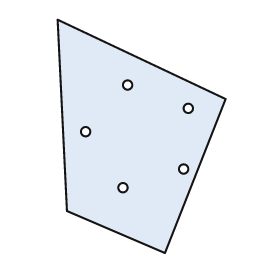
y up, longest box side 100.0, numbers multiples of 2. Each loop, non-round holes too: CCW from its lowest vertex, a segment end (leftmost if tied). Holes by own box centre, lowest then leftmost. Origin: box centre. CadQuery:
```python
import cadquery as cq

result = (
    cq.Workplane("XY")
    .moveTo(10.0, -50.0)
    .lineTo(36.0, 16.0)
    .lineTo(-36.0, 50.0)
    .lineTo(-32.0, -32.0)
    .close()
    .moveTo(-8.0, -22.0)
    .circle(2.0)
    .moveTo(18.0, -14.0)
    .circle(2.0)
    .moveTo(-24.0, 2.0)
    .circle(2.0)
    .moveTo(20.0, 12.0)
    .circle(2.0)
    .moveTo(-6.0, 22.0)
    .circle(2.0)
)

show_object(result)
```